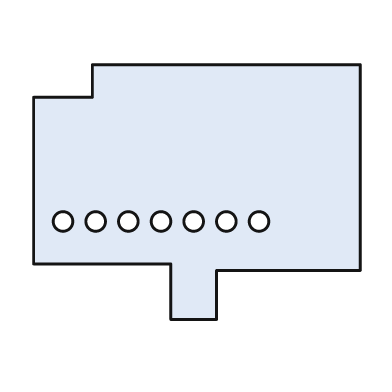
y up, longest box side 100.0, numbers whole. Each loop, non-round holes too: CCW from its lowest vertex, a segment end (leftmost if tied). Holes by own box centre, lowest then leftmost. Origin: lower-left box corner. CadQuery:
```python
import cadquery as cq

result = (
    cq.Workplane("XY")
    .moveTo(42.0, 0.0)
    .lineTo(56.0, 0.0)
    .lineTo(56.0, 15.0)
    .lineTo(100.0, 15.0)
    .lineTo(100.0, 78.0)
    .lineTo(18.0, 78.0)
    .lineTo(18.0, 68.0)
    .lineTo(0.0, 68.0)
    .lineTo(0.0, 17.0)
    .lineTo(42.0, 17.0)
    .close()
    .moveTo(9.0, 30.0)
    .circle(3.0)
    .moveTo(19.0, 30.0)
    .circle(3.0)
    .moveTo(29.0, 30.0)
    .circle(3.0)
    .moveTo(39.0, 30.0)
    .circle(3.0)
    .moveTo(49.0, 30.0)
    .circle(3.0)
    .moveTo(59.0, 30.0)
    .circle(3.0)
    .moveTo(69.0, 30.0)
    .circle(3.0)
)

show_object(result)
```